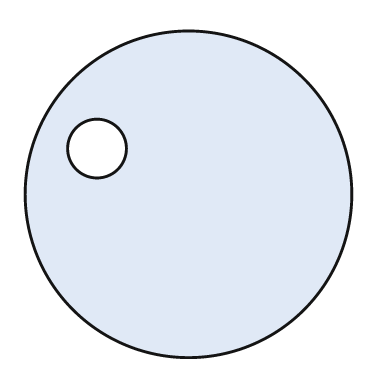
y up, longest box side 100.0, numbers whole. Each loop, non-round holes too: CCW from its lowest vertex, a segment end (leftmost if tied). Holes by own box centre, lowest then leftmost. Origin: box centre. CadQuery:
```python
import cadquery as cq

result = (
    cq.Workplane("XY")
    .moveTo(0.0, 0.0)
    .circle(50.0)
    .moveTo(-28.0, 14.0)
    .circle(9.0)
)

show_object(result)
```